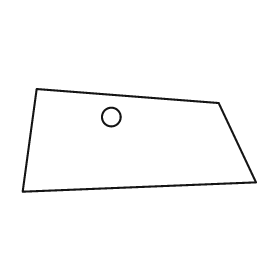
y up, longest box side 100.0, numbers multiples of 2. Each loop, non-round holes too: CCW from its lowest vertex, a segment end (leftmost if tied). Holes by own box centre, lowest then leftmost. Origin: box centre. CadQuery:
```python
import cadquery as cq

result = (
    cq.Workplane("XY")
    .moveTo(-50.0, -22.0)
    .lineTo(50.0, -18.0)
    .lineTo(34.0, 16.0)
    .lineTo(-44.0, 22.0)
    .close()
    .moveTo(-12.0, 10.0)
    .circle(4.0)
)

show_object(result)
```